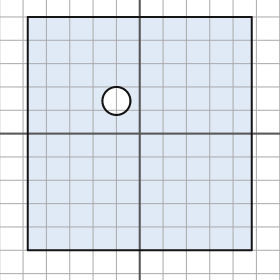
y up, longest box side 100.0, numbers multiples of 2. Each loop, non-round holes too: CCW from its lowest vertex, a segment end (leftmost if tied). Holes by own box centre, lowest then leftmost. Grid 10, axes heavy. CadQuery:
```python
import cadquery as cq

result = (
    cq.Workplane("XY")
    .moveTo(-48.0, -50.0)
    .lineTo(48.0, -50.0)
    .lineTo(48.0, 50.0)
    .lineTo(-48.0, 50.0)
    .close()
    .moveTo(-10.0, 14.0)
    .circle(6.0)
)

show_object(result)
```